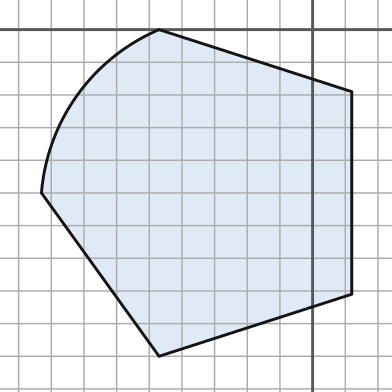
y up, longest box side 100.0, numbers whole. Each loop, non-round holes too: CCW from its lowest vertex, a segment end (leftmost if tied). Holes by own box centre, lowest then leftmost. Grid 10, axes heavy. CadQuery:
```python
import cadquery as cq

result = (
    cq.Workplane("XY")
    .moveTo(-47.0, -100.0)
    .lineTo(12.0, -81.0)
    .lineTo(12.0, -19.0)
    .lineTo(-47.0, 0.0)
    .threePointArc((-72.0, -20.0), (-83.0, -50.0))
    .close()
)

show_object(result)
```